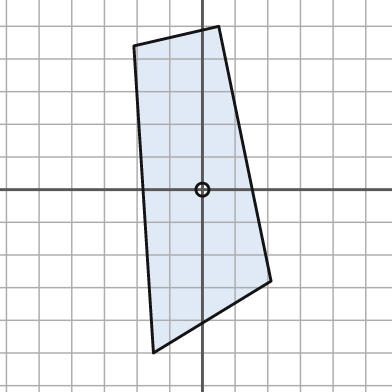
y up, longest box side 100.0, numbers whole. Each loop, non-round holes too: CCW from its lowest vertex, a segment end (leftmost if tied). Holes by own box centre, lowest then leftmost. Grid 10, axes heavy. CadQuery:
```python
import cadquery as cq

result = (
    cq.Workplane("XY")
    .moveTo(-15.0, -50.0)
    .lineTo(21.0, -28.0)
    .lineTo(5.0, 50.0)
    .lineTo(-21.0, 44.0)
    .close()
    .moveTo(0.0, 0.0)
    .circle(2.0)
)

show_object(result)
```